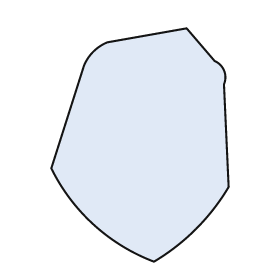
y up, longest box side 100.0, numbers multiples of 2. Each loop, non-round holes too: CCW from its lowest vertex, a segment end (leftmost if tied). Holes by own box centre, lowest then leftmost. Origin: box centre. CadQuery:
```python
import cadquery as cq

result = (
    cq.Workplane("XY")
    .moveTo(6.0, -50.0)
    .threePointArc((24.0, -36.0), (38.0, -18.0))
    .lineTo(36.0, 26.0)
    .threePointArc((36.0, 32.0), (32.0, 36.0))
    .lineTo(20.0, 50.0)
    .lineTo(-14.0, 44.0)
    .threePointArc((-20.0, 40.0), (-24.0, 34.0))
    .lineTo(-38.0, -10.0)
    .threePointArc((-20.0, -34.0), (6.0, -50.0))
    .close()
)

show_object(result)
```